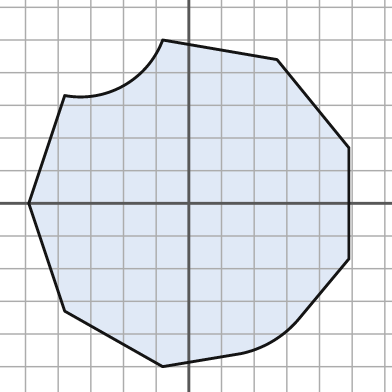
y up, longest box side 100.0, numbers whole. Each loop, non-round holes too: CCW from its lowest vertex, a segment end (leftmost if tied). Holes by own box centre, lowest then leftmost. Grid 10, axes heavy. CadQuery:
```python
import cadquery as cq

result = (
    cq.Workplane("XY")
    .moveTo(-8.0, -50.0)
    .lineTo(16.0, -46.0)
    .threePointArc((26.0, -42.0), (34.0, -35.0))
    .lineTo(49.0, -17.0)
    .lineTo(49.0, 17.0)
    .lineTo(27.0, 44.0)
    .lineTo(-8.0, 50.0)
    .threePointArc((-20.0, 36.0), (-38.0, 33.0))
    .lineTo(-49.0, 0.0)
    .lineTo(-38.0, -33.0)
    .close()
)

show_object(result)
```